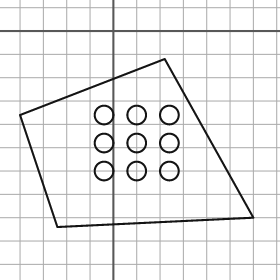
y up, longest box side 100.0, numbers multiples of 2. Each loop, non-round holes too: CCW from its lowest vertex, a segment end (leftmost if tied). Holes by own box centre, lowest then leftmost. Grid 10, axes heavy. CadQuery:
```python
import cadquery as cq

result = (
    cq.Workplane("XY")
    .moveTo(-24.0, -84.0)
    .lineTo(60.0, -80.0)
    .lineTo(22.0, -12.0)
    .lineTo(-40.0, -36.0)
    .close()
    .moveTo(-4.0, -60.0)
    .circle(4.0)
    .moveTo(10.0, -60.0)
    .circle(4.0)
    .moveTo(24.0, -60.0)
    .circle(4.0)
    .moveTo(-4.0, -48.0)
    .circle(4.0)
    .moveTo(10.0, -48.0)
    .circle(4.0)
    .moveTo(24.0, -48.0)
    .circle(4.0)
    .moveTo(-4.0, -36.0)
    .circle(4.0)
    .moveTo(10.0, -36.0)
    .circle(4.0)
    .moveTo(24.0, -36.0)
    .circle(4.0)
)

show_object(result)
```